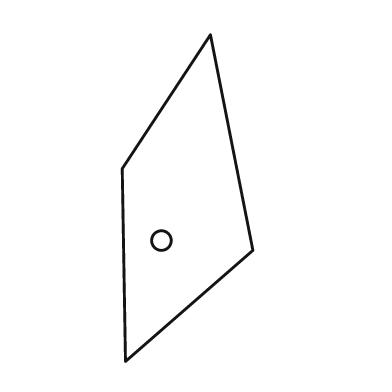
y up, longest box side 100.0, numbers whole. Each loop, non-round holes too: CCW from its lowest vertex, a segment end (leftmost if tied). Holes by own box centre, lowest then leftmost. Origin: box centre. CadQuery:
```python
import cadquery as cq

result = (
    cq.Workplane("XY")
    .moveTo(-19.0, -50.0)
    .lineTo(20.0, -16.0)
    .lineTo(7.0, 50.0)
    .lineTo(-20.0, 9.0)
    .close()
    .moveTo(-8.0, -13.0)
    .circle(3.0)
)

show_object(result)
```